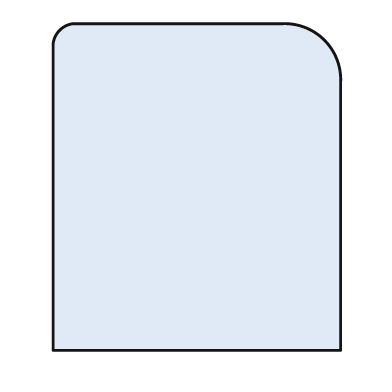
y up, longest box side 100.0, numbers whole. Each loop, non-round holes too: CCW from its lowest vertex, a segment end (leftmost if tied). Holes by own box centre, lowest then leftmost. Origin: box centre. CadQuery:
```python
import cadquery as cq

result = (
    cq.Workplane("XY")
    .moveTo(-44.0, -50.0)
    .lineTo(44.0, -50.0)
    .lineTo(44.0, 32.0)
    .threePointArc((39.0, 45.0), (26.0, 50.0))
    .lineTo(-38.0, 50.0)
    .threePointArc((-42.0, 48.0), (-44.0, 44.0))
    .close()
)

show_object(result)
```